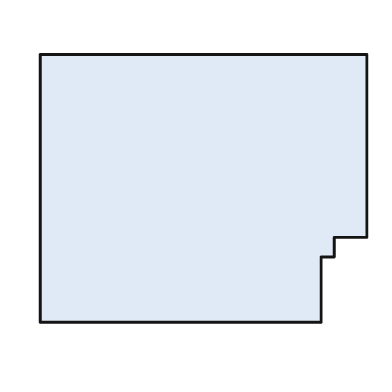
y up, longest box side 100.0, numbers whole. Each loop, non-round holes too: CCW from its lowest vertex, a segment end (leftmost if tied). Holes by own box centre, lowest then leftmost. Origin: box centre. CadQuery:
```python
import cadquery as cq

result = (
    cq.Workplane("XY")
    .moveTo(-50.0, -41.0)
    .lineTo(36.0, -41.0)
    .lineTo(36.0, -21.0)
    .lineTo(40.0, -21.0)
    .lineTo(40.0, -15.0)
    .lineTo(50.0, -15.0)
    .lineTo(50.0, 41.0)
    .lineTo(-50.0, 41.0)
    .close()
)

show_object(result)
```